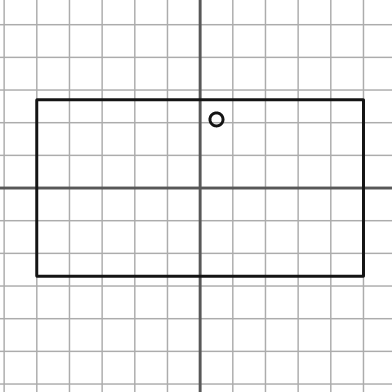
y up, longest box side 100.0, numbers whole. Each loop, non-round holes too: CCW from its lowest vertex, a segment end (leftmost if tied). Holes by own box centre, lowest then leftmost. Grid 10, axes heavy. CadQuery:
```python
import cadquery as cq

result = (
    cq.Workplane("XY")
    .moveTo(-50.0, -27.0)
    .lineTo(50.0, -27.0)
    .lineTo(50.0, 27.0)
    .lineTo(-50.0, 27.0)
    .close()
    .moveTo(5.0, 21.0)
    .circle(2.0)
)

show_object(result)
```